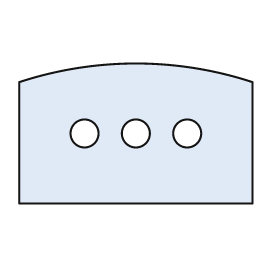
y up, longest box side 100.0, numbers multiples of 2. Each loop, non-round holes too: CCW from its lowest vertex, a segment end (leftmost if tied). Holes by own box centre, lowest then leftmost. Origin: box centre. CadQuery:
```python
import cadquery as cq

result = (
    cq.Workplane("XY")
    .moveTo(-50.0, -30.0)
    .lineTo(50.0, -30.0)
    .lineTo(50.0, 22.0)
    .threePointArc((0.0, 30.0), (-50.0, 22.0))
    .close()
    .moveTo(-22.0, 0.0)
    .circle(6.0)
    .moveTo(0.0, 0.0)
    .circle(6.0)
    .moveTo(22.0, 0.0)
    .circle(6.0)
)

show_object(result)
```